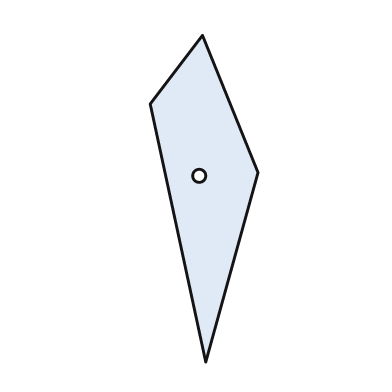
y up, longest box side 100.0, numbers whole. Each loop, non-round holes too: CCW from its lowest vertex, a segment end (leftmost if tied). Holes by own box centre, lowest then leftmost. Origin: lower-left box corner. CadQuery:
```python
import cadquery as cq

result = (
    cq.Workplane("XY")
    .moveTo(17.0, 0.0)
    .lineTo(33.0, 58.0)
    .lineTo(16.0, 100.0)
    .lineTo(0.0, 79.0)
    .close()
    .moveTo(15.0, 57.0)
    .circle(2.0)
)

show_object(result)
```